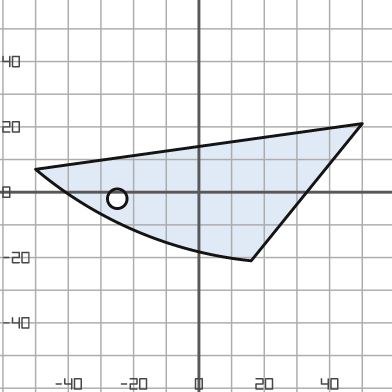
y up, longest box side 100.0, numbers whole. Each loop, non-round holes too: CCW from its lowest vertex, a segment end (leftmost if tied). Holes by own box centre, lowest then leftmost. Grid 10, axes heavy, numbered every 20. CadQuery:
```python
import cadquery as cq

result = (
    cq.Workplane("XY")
    .moveTo(16.0, -21.0)
    .lineTo(50.0, 21.0)
    .lineTo(-50.0, 7.0)
    .threePointArc((-19.0, -12.0), (16.0, -21.0))
    .close()
    .moveTo(-25.0, -2.0)
    .circle(3.0)
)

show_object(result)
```